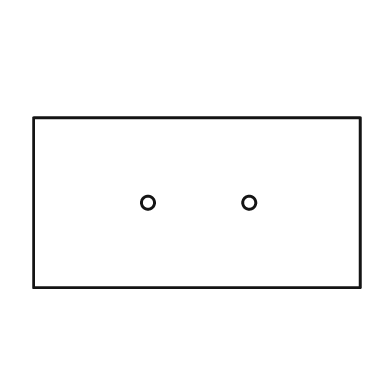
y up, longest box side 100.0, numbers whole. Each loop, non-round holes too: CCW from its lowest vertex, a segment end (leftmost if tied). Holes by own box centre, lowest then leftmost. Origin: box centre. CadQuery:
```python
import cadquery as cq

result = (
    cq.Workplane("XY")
    .moveTo(-50.0, -26.0)
    .lineTo(50.0, -26.0)
    .lineTo(50.0, 26.0)
    .lineTo(-50.0, 26.0)
    .close()
    .moveTo(-15.0, 0.0)
    .circle(2.0)
    .moveTo(16.0, 0.0)
    .circle(2.0)
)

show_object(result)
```